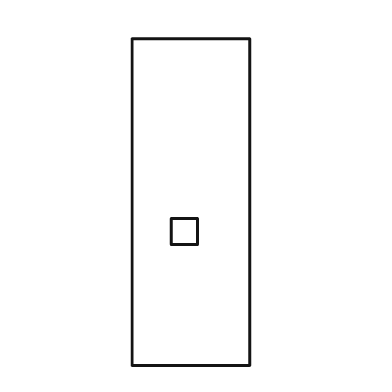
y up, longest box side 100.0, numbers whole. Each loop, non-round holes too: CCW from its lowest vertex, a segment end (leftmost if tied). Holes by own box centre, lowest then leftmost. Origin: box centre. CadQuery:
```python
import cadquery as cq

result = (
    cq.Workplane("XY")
    .moveTo(-18.0, -50.0)
    .lineTo(18.0, -50.0)
    .lineTo(18.0, 50.0)
    .lineTo(-18.0, 50.0)
    .close()
    .moveTo(-6.0, -13.0)
    .lineTo(2.0, -13.0)
    .lineTo(2.0, -5.0)
    .lineTo(-6.0, -5.0)
    .close()
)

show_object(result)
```